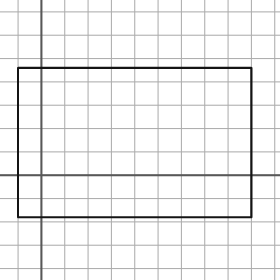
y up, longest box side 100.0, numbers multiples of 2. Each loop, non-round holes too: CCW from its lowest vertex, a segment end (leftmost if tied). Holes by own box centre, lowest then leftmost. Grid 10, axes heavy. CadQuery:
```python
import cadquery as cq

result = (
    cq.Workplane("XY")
    .moveTo(-10.0, -18.0)
    .lineTo(90.0, -18.0)
    .lineTo(90.0, 46.0)
    .lineTo(-10.0, 46.0)
    .close()
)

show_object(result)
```